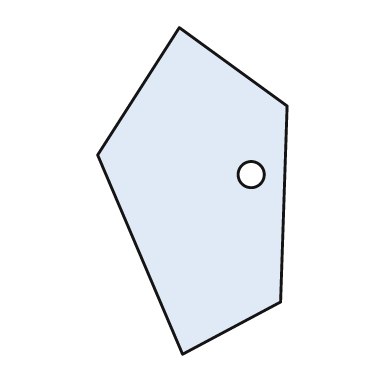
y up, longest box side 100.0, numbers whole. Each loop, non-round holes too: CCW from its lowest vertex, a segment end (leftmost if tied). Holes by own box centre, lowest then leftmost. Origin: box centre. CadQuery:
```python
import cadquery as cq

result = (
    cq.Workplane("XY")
    .moveTo(-3.0, -50.0)
    .lineTo(27.0, -34.0)
    .lineTo(29.0, 26.0)
    .lineTo(-4.0, 50.0)
    .lineTo(-29.0, 11.0)
    .close()
    .moveTo(18.0, 5.0)
    .circle(4.0)
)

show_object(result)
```